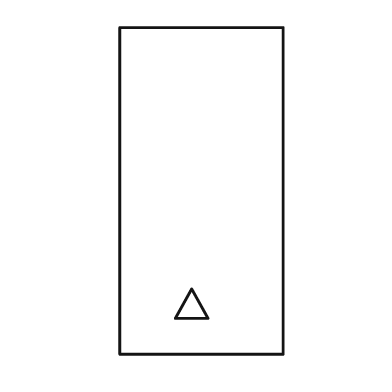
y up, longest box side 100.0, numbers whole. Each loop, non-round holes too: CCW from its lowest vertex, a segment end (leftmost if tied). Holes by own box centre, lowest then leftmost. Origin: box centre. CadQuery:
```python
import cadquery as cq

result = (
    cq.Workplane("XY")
    .moveTo(-25.0, -50.0)
    .lineTo(25.0, -50.0)
    .lineTo(25.0, 50.0)
    .lineTo(-25.0, 50.0)
    .close()
    .moveTo(-8.0, -39.0)
    .lineTo(2.0, -39.0)
    .lineTo(-3.0, -30.0)
    .close()
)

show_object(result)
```